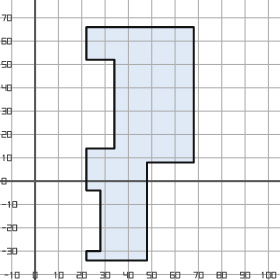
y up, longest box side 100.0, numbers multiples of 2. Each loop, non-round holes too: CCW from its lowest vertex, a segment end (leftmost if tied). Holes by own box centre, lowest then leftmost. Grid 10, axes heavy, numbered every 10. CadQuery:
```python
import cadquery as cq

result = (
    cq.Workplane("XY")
    .moveTo(22.0, -34.0)
    .lineTo(48.0, -34.0)
    .lineTo(48.0, 8.0)
    .lineTo(68.0, 8.0)
    .lineTo(68.0, 66.0)
    .lineTo(22.0, 66.0)
    .lineTo(22.0, 52.0)
    .lineTo(34.0, 52.0)
    .lineTo(34.0, 14.0)
    .lineTo(22.0, 14.0)
    .lineTo(22.0, -4.0)
    .lineTo(28.0, -4.0)
    .lineTo(28.0, -30.0)
    .lineTo(22.0, -30.0)
    .close()
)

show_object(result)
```